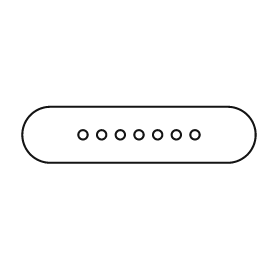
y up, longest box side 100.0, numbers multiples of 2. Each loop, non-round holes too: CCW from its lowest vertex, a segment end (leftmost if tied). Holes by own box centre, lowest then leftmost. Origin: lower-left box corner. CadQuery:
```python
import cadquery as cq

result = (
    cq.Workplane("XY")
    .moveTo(12.0, 0.0)
    .lineTo(88.0, 0.0)
    .threePointArc((100.0, 12.0), (88.0, 24.0))
    .lineTo(12.0, 24.0)
    .threePointArc((0.0, 12.0), (12.0, 0.0))
    .close()
    .moveTo(26.0, 12.0)
    .circle(2.0)
    .moveTo(34.0, 12.0)
    .circle(2.0)
    .moveTo(42.0, 12.0)
    .circle(2.0)
    .moveTo(50.0, 12.0)
    .circle(2.0)
    .moveTo(58.0, 12.0)
    .circle(2.0)
    .moveTo(66.0, 12.0)
    .circle(2.0)
    .moveTo(74.0, 12.0)
    .circle(2.0)
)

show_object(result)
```